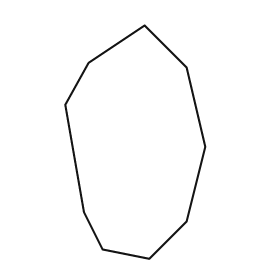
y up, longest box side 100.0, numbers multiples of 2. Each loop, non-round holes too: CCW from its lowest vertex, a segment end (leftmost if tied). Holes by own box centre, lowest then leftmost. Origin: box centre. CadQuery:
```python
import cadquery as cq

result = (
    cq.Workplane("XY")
    .moveTo(6.0, -50.0)
    .lineTo(22.0, -34.0)
    .lineTo(30.0, -2.0)
    .lineTo(22.0, 32.0)
    .lineTo(4.0, 50.0)
    .lineTo(-20.0, 34.0)
    .lineTo(-30.0, 16.0)
    .lineTo(-22.0, -30.0)
    .lineTo(-14.0, -46.0)
    .close()
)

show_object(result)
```